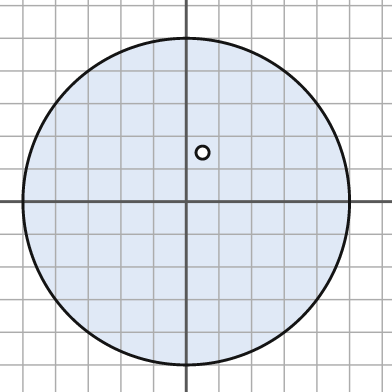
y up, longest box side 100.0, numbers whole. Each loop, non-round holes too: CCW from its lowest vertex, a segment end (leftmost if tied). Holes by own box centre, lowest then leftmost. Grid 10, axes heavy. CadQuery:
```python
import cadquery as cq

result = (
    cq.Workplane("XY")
    .moveTo(0.0, 0.0)
    .circle(50.0)
    .moveTo(5.0, 15.0)
    .circle(2.0)
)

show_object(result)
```